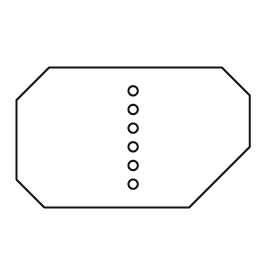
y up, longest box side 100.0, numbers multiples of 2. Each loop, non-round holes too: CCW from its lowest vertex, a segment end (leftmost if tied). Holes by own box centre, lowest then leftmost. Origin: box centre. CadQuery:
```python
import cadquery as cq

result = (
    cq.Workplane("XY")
    .moveTo(-38.0, -30.0)
    .lineTo(24.0, -30.0)
    .lineTo(50.0, -4.0)
    .lineTo(50.0, 18.0)
    .lineTo(38.0, 30.0)
    .lineTo(-36.0, 30.0)
    .lineTo(-50.0, 16.0)
    .lineTo(-50.0, -18.0)
    .close()
    .moveTo(0.0, -20.0)
    .circle(2.0)
    .moveTo(0.0, -12.0)
    .circle(2.0)
    .moveTo(0.0, -4.0)
    .circle(2.0)
    .moveTo(0.0, 4.0)
    .circle(2.0)
    .moveTo(0.0, 12.0)
    .circle(2.0)
    .moveTo(0.0, 20.0)
    .circle(2.0)
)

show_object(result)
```